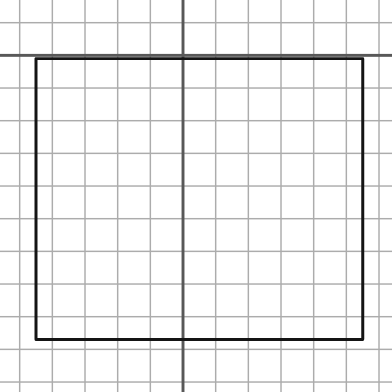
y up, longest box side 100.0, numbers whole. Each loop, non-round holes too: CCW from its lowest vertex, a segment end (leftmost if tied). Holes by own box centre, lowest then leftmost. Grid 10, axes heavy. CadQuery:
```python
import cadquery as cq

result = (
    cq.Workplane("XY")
    .moveTo(-45.0, -87.0)
    .lineTo(55.0, -87.0)
    .lineTo(55.0, -1.0)
    .lineTo(-45.0, -1.0)
    .close()
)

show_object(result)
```